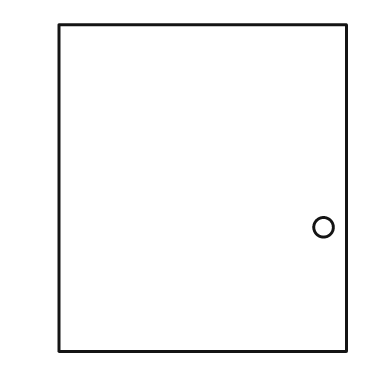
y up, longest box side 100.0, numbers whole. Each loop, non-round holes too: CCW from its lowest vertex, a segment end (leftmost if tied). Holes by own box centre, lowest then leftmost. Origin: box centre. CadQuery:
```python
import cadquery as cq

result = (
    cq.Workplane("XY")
    .moveTo(-44.0, -50.0)
    .lineTo(44.0, -50.0)
    .lineTo(44.0, 50.0)
    .lineTo(-44.0, 50.0)
    .close()
    .moveTo(37.0, -12.0)
    .circle(3.0)
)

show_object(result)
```